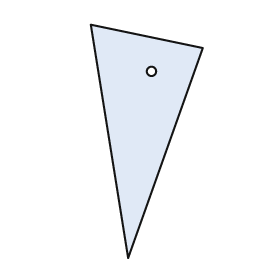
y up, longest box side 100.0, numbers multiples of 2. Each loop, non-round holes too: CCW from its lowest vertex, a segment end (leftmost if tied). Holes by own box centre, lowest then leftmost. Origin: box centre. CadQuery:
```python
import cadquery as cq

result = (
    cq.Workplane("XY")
    .moveTo(-8.0, -50.0)
    .lineTo(24.0, 40.0)
    .lineTo(-24.0, 50.0)
    .close()
    .moveTo(2.0, 30.0)
    .circle(2.0)
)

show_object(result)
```